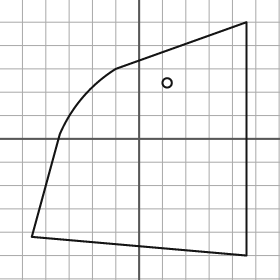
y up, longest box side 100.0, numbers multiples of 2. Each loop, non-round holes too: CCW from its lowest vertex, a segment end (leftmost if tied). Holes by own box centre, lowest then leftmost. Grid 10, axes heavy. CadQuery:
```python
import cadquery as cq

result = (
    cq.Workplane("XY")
    .moveTo(46.0, -50.0)
    .lineTo(46.0, 50.0)
    .lineTo(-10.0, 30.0)
    .threePointArc((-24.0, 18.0), (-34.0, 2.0))
    .lineTo(-46.0, -42.0)
    .close()
    .moveTo(12.0, 24.0)
    .circle(2.0)
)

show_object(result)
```